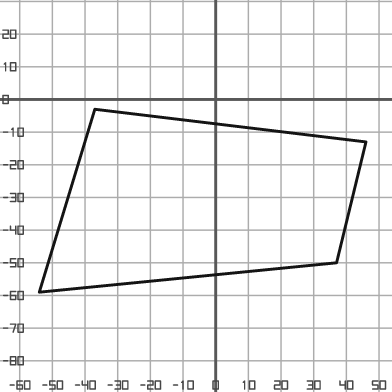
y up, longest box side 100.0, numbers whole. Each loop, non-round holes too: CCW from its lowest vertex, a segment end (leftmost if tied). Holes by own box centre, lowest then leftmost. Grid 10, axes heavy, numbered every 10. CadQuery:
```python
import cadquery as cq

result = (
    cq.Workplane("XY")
    .moveTo(-54.0, -59.0)
    .lineTo(37.0, -50.0)
    .lineTo(46.0, -13.0)
    .lineTo(-37.0, -3.0)
    .close()
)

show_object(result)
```